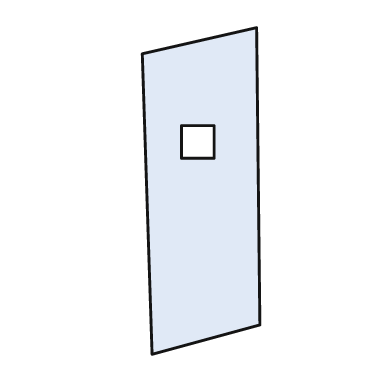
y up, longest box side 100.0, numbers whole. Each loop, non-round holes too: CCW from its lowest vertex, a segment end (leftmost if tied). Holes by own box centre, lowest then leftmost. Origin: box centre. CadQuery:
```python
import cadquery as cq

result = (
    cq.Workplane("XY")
    .moveTo(-15.0, -50.0)
    .lineTo(18.0, -41.0)
    .lineTo(17.0, 50.0)
    .lineTo(-18.0, 42.0)
    .close()
    .moveTo(-6.0, 10.0)
    .lineTo(4.0, 10.0)
    .lineTo(4.0, 20.0)
    .lineTo(-6.0, 20.0)
    .close()
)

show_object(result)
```